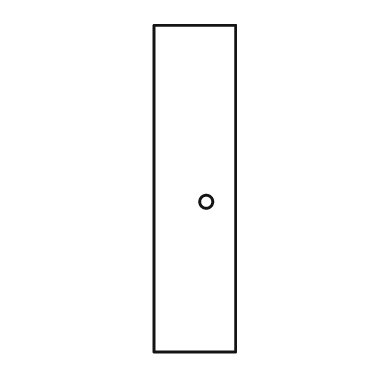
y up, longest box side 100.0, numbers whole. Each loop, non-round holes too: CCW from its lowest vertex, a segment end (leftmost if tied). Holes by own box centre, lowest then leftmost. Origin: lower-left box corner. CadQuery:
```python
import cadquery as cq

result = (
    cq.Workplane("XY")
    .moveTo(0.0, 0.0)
    .lineTo(25.0, 0.0)
    .lineTo(25.0, 100.0)
    .lineTo(0.0, 100.0)
    .close()
    .moveTo(16.0, 46.0)
    .circle(2.0)
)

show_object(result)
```